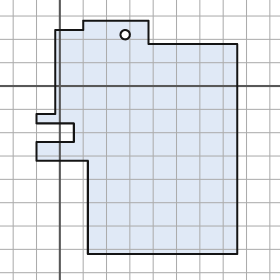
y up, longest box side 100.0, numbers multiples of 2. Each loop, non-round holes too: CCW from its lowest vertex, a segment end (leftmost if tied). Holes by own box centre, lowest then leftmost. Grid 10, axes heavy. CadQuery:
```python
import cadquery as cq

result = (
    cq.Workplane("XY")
    .moveTo(12.0, -72.0)
    .lineTo(76.0, -72.0)
    .lineTo(76.0, 18.0)
    .lineTo(38.0, 18.0)
    .lineTo(38.0, 28.0)
    .lineTo(10.0, 28.0)
    .lineTo(10.0, 24.0)
    .lineTo(-2.0, 24.0)
    .lineTo(-2.0, -12.0)
    .lineTo(-10.0, -12.0)
    .lineTo(-10.0, -16.0)
    .lineTo(6.0, -16.0)
    .lineTo(6.0, -24.0)
    .lineTo(-10.0, -24.0)
    .lineTo(-10.0, -32.0)
    .lineTo(12.0, -32.0)
    .close()
    .moveTo(28.0, 22.0)
    .circle(2.0)
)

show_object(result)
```